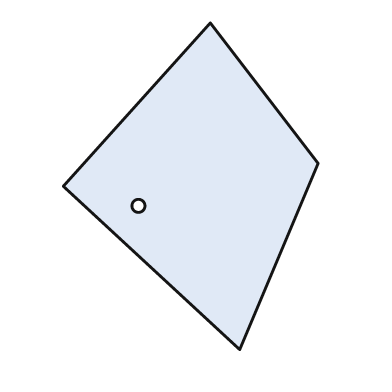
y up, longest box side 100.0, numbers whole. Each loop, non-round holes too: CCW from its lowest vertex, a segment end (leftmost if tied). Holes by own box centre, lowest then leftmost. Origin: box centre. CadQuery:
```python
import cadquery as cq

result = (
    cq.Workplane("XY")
    .moveTo(15.0, -50.0)
    .lineTo(39.0, 7.0)
    .lineTo(6.0, 50.0)
    .lineTo(-39.0, 0.0)
    .close()
    .moveTo(-16.0, -6.0)
    .circle(2.0)
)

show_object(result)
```